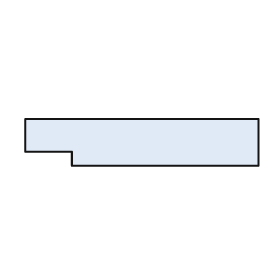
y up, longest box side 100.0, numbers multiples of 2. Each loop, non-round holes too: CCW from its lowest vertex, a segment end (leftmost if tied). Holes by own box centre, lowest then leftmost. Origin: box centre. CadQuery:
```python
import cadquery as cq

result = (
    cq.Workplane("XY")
    .moveTo(-30.0, -10.0)
    .lineTo(50.0, -10.0)
    .lineTo(50.0, 10.0)
    .lineTo(-50.0, 10.0)
    .lineTo(-50.0, -4.0)
    .lineTo(-30.0, -4.0)
    .close()
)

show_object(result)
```